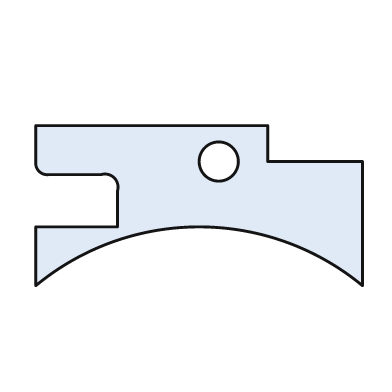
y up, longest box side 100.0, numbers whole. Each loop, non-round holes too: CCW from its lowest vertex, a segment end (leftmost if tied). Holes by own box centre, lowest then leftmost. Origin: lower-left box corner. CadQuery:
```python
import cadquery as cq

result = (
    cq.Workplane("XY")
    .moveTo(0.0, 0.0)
    .threePointArc((50.0, 18.0), (100.0, 0.0))
    .lineTo(100.0, 38.0)
    .lineTo(71.0, 38.0)
    .lineTo(71.0, 49.0)
    .lineTo(0.0, 49.0)
    .lineTo(0.0, 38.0)
    .threePointArc((1.0, 35.0), (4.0, 34.0))
    .lineTo(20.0, 34.0)
    .threePointArc((24.0, 33.0), (25.0, 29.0))
    .lineTo(25.0, 18.0)
    .lineTo(0.0, 18.0)
    .close()
    .moveTo(56.0, 38.0)
    .circle(6.0)
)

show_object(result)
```